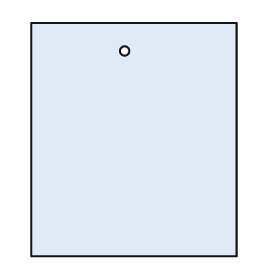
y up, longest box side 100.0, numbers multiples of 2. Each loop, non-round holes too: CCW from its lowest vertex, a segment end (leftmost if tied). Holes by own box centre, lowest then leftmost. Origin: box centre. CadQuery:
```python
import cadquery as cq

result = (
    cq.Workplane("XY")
    .moveTo(-44.0, -50.0)
    .lineTo(44.0, -50.0)
    .lineTo(44.0, 50.0)
    .lineTo(-44.0, 50.0)
    .close()
    .moveTo(-4.0, 38.0)
    .circle(2.0)
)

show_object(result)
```